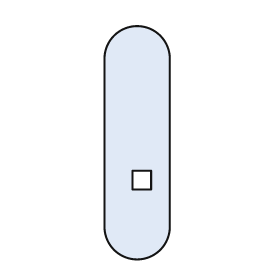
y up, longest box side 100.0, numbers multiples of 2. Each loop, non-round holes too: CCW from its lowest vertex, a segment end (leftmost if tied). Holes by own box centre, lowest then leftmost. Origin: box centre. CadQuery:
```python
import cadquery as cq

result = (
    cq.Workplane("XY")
    .moveTo(-14.0, -36.0)
    .threePointArc((0.0, -50.0), (14.0, -36.0))
    .lineTo(14.0, 36.0)
    .threePointArc((0.0, 50.0), (-14.0, 36.0))
    .close()
    .moveTo(-2.0, -20.0)
    .lineTo(6.0, -20.0)
    .lineTo(6.0, -12.0)
    .lineTo(-2.0, -12.0)
    .close()
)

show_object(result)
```